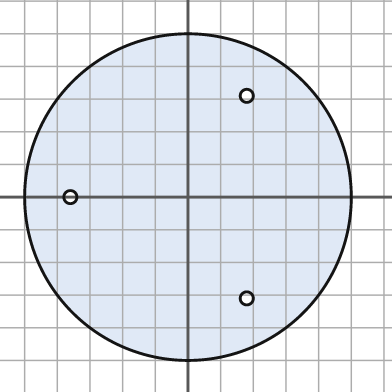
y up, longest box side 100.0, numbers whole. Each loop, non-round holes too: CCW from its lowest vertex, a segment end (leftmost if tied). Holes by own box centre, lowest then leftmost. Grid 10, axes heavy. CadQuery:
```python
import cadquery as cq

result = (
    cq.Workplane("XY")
    .moveTo(0.0, 0.0)
    .circle(50.0)
    .moveTo(18.0, -31.0)
    .circle(2.0)
    .moveTo(-36.0, 0.0)
    .circle(2.0)
    .moveTo(18.0, 31.0)
    .circle(2.0)
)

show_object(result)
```